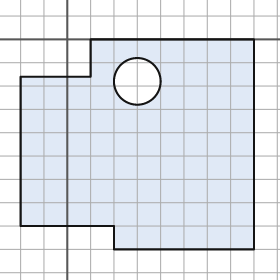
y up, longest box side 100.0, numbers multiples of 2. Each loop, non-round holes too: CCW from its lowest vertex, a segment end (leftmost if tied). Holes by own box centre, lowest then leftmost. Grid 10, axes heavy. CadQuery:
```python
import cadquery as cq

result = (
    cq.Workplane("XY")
    .moveTo(20.0, -90.0)
    .lineTo(80.0, -90.0)
    .lineTo(80.0, 0.0)
    .lineTo(10.0, 0.0)
    .lineTo(10.0, -16.0)
    .lineTo(-20.0, -16.0)
    .lineTo(-20.0, -80.0)
    .lineTo(20.0, -80.0)
    .close()
    .moveTo(30.0, -18.0)
    .circle(10.0)
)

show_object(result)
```